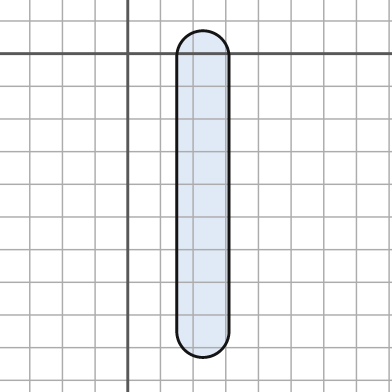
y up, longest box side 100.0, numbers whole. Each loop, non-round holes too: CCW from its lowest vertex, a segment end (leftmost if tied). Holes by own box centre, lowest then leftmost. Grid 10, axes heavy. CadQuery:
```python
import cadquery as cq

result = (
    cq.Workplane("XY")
    .moveTo(15.0, -85.0)
    .threePointArc((23.0, -93.0), (31.0, -85.0))
    .lineTo(31.0, -1.0)
    .threePointArc((23.0, 7.0), (15.0, -1.0))
    .close()
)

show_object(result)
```